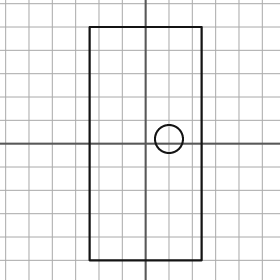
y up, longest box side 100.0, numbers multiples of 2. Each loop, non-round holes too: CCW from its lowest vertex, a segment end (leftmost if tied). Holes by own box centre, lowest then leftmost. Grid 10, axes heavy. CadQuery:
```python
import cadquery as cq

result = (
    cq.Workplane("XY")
    .moveTo(-24.0, -50.0)
    .lineTo(24.0, -50.0)
    .lineTo(24.0, 50.0)
    .lineTo(-24.0, 50.0)
    .close()
    .moveTo(10.0, 2.0)
    .circle(6.0)
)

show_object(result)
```